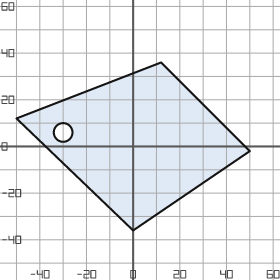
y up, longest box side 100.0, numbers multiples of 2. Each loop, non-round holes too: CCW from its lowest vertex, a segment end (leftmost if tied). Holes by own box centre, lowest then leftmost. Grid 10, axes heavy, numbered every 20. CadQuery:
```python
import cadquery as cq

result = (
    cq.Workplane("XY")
    .moveTo(0.0, -36.0)
    .lineTo(50.0, -2.0)
    .lineTo(12.0, 36.0)
    .lineTo(-50.0, 12.0)
    .close()
    .moveTo(-30.0, 6.0)
    .circle(4.0)
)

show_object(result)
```